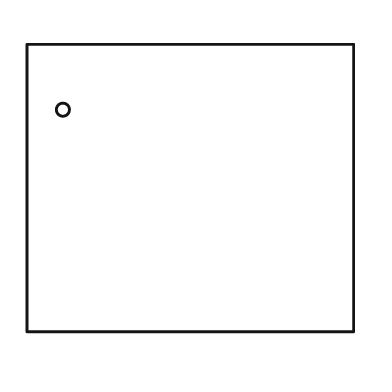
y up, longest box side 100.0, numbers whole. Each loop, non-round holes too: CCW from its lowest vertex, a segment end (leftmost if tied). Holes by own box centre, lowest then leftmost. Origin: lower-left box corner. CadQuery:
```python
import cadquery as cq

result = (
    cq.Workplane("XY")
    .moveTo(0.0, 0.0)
    .lineTo(100.0, 0.0)
    .lineTo(100.0, 88.0)
    .lineTo(0.0, 88.0)
    .close()
    .moveTo(11.0, 68.0)
    .circle(2.0)
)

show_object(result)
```